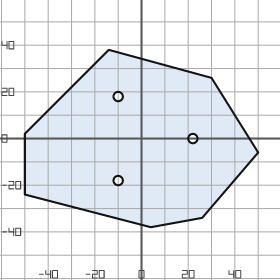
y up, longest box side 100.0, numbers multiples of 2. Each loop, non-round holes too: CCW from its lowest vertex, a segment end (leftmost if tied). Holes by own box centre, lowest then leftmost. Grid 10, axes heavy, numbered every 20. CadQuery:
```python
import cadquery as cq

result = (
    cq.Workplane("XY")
    .moveTo(4.0, -38.0)
    .lineTo(26.0, -34.0)
    .lineTo(50.0, -6.0)
    .lineTo(30.0, 26.0)
    .lineTo(-14.0, 38.0)
    .lineTo(-50.0, 2.0)
    .lineTo(-50.0, -24.0)
    .close()
    .moveTo(-10.0, -18.0)
    .circle(2.0)
    .moveTo(22.0, 0.0)
    .circle(2.0)
    .moveTo(-10.0, 18.0)
    .circle(2.0)
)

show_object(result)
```